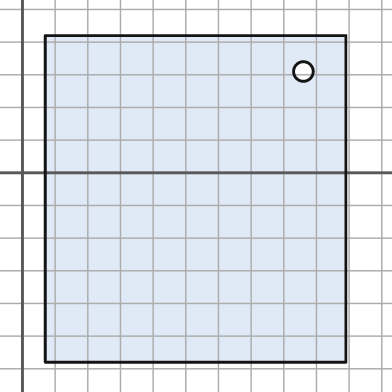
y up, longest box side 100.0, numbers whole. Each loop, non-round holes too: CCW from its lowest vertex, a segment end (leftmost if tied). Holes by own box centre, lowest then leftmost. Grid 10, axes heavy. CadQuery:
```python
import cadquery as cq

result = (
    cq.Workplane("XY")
    .moveTo(7.0, -58.0)
    .lineTo(99.0, -58.0)
    .lineTo(99.0, 42.0)
    .lineTo(7.0, 42.0)
    .close()
    .moveTo(86.0, 31.0)
    .circle(3.0)
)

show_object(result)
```